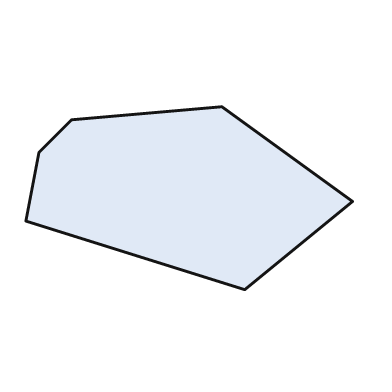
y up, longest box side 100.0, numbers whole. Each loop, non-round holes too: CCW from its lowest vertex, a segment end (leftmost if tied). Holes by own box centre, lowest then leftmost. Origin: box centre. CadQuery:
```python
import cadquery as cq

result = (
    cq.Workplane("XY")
    .moveTo(17.0, -28.0)
    .lineTo(50.0, -1.0)
    .lineTo(10.0, 28.0)
    .lineTo(-36.0, 24.0)
    .lineTo(-46.0, 14.0)
    .lineTo(-50.0, -7.0)
    .close()
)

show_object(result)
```